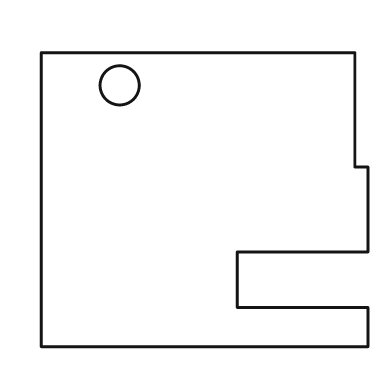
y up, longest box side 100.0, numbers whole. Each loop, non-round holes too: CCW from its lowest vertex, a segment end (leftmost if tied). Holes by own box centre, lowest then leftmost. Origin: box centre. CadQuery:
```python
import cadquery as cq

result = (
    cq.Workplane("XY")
    .moveTo(-50.0, -45.0)
    .lineTo(50.0, -45.0)
    .lineTo(50.0, -33.0)
    .lineTo(10.0, -33.0)
    .lineTo(10.0, -16.0)
    .lineTo(50.0, -16.0)
    .lineTo(50.0, 10.0)
    .lineTo(46.0, 10.0)
    .lineTo(46.0, 45.0)
    .lineTo(-50.0, 45.0)
    .close()
    .moveTo(-26.0, 35.0)
    .circle(6.0)
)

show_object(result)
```